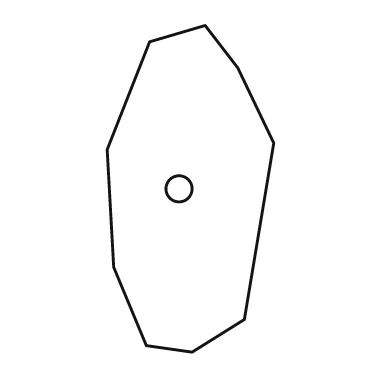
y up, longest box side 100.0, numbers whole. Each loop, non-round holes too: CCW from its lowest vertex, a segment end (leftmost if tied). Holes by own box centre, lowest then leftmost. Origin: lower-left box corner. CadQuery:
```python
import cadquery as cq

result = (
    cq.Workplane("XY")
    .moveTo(26.0, 0.0)
    .lineTo(42.0, 10.0)
    .lineTo(51.0, 64.0)
    .lineTo(40.0, 87.0)
    .lineTo(30.0, 100.0)
    .lineTo(13.0, 95.0)
    .lineTo(0.0, 62.0)
    .lineTo(2.0, 26.0)
    .lineTo(12.0, 2.0)
    .close()
    .moveTo(22.0, 50.0)
    .circle(4.0)
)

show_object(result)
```